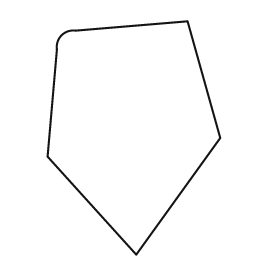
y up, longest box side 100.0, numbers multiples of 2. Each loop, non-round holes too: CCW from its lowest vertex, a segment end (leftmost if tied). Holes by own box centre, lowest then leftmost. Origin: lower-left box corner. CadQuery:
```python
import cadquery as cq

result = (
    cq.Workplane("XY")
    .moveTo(38.0, 0.0)
    .lineTo(74.0, 50.0)
    .lineTo(60.0, 100.0)
    .lineTo(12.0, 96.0)
    .threePointArc((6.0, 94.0), (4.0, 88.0))
    .lineTo(0.0, 42.0)
    .close()
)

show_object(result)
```